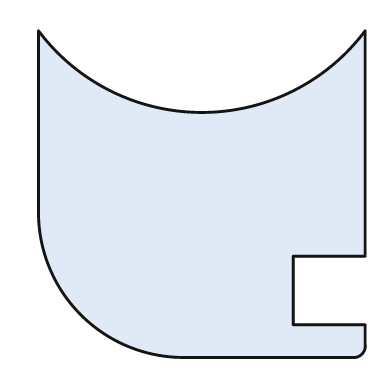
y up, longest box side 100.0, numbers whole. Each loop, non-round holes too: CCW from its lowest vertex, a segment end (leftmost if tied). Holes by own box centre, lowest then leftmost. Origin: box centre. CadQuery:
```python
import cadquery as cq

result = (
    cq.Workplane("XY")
    .moveTo(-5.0, -50.0)
    .lineTo(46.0, -50.0)
    .threePointArc((49.0, -49.0), (50.0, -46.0))
    .lineTo(50.0, -40.0)
    .lineTo(28.0, -40.0)
    .lineTo(28.0, -19.0)
    .lineTo(50.0, -19.0)
    .lineTo(50.0, 50.0)
    .threePointArc((0.0, 25.0), (-50.0, 50.0))
    .lineTo(-50.0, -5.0)
    .threePointArc((-37.0, -37.0), (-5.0, -50.0))
    .close()
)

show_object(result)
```